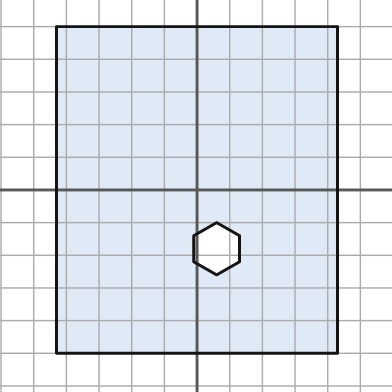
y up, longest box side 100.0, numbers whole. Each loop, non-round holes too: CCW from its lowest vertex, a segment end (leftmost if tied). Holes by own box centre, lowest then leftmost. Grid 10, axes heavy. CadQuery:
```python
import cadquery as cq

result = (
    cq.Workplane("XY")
    .moveTo(-43.0, -50.0)
    .lineTo(43.0, -50.0)
    .lineTo(43.0, 50.0)
    .lineTo(-43.0, 50.0)
    .close()
    .moveTo(6.0, -26.0)
    .lineTo(13.0, -22.0)
    .lineTo(13.0, -14.0)
    .lineTo(6.0, -10.0)
    .lineTo(-1.0, -14.0)
    .lineTo(-1.0, -22.0)
    .close()
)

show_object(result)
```